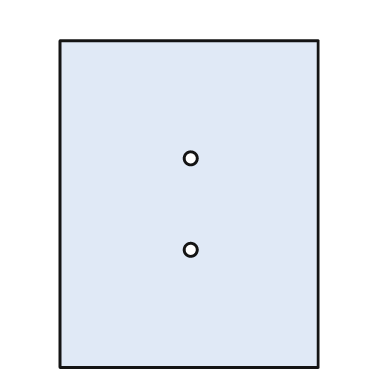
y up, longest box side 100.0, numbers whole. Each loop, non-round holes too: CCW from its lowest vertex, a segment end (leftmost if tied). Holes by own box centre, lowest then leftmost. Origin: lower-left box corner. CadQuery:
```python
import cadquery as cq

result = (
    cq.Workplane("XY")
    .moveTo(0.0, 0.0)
    .lineTo(79.0, 0.0)
    .lineTo(79.0, 100.0)
    .lineTo(0.0, 100.0)
    .close()
    .moveTo(40.0, 36.0)
    .circle(2.0)
    .moveTo(40.0, 64.0)
    .circle(2.0)
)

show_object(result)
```